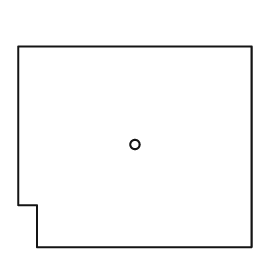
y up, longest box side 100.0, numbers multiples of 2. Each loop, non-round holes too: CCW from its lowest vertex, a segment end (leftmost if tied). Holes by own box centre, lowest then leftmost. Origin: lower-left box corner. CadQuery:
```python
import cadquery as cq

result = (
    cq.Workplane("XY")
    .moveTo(8.0, 0.0)
    .lineTo(100.0, 0.0)
    .lineTo(100.0, 86.0)
    .lineTo(0.0, 86.0)
    .lineTo(0.0, 18.0)
    .lineTo(8.0, 18.0)
    .close()
    .moveTo(50.0, 44.0)
    .circle(2.0)
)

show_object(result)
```